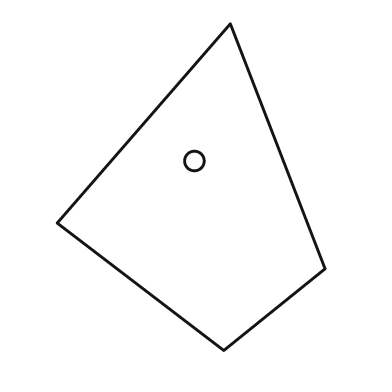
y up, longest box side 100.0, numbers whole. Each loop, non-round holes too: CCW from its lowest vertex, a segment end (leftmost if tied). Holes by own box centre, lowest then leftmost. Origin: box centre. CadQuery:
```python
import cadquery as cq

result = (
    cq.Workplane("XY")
    .moveTo(10.0, -50.0)
    .lineTo(41.0, -25.0)
    .lineTo(12.0, 50.0)
    .lineTo(-41.0, -11.0)
    .close()
    .moveTo(1.0, 8.0)
    .circle(3.0)
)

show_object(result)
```